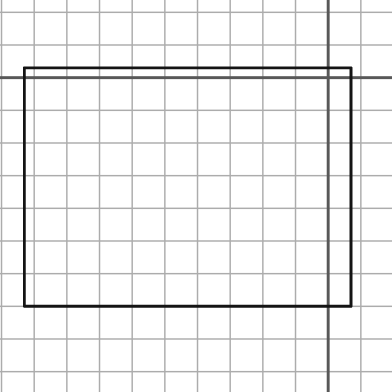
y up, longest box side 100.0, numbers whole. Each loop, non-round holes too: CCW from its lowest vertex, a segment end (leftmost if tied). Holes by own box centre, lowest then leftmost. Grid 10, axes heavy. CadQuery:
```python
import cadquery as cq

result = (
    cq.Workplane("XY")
    .moveTo(-93.0, -70.0)
    .lineTo(7.0, -70.0)
    .lineTo(7.0, 3.0)
    .lineTo(-93.0, 3.0)
    .close()
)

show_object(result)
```